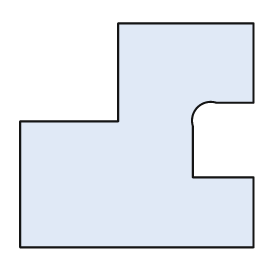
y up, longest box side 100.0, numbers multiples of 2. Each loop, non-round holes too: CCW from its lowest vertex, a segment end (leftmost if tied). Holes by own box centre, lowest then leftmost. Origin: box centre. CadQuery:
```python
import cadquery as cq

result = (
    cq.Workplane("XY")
    .moveTo(-50.0, -48.0)
    .lineTo(50.0, -48.0)
    .lineTo(50.0, -18.0)
    .lineTo(24.0, -18.0)
    .lineTo(24.0, 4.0)
    .threePointArc((26.0, 12.0), (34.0, 14.0))
    .lineTo(50.0, 14.0)
    .lineTo(50.0, 48.0)
    .lineTo(-8.0, 48.0)
    .lineTo(-8.0, 6.0)
    .lineTo(-50.0, 6.0)
    .close()
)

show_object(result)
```